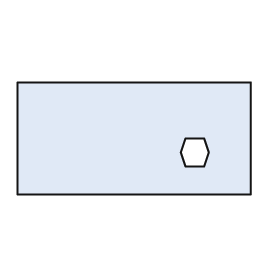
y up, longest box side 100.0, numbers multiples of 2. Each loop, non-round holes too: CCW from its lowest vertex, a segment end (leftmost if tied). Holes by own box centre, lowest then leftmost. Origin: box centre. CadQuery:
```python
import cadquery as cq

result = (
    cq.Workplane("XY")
    .moveTo(-50.0, -24.0)
    .lineTo(50.0, -24.0)
    .lineTo(50.0, 24.0)
    .lineTo(-50.0, 24.0)
    .close()
    .moveTo(22.0, -12.0)
    .lineTo(30.0, -12.0)
    .lineTo(32.0, -6.0)
    .lineTo(30.0, 0.0)
    .lineTo(22.0, 0.0)
    .lineTo(20.0, -6.0)
    .close()
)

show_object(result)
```